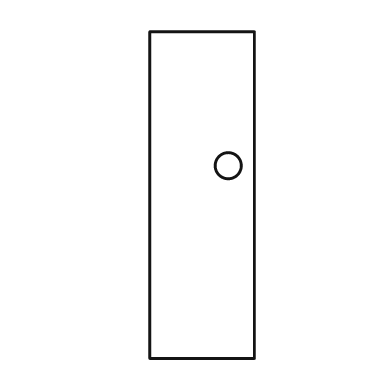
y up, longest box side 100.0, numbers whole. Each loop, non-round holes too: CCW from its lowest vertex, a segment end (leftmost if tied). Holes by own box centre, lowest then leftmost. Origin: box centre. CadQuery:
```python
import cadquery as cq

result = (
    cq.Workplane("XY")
    .moveTo(-16.0, -50.0)
    .lineTo(16.0, -50.0)
    .lineTo(16.0, 50.0)
    .lineTo(-16.0, 50.0)
    .close()
    .moveTo(8.0, 9.0)
    .circle(4.0)
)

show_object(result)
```